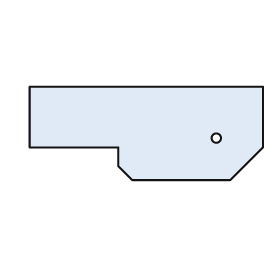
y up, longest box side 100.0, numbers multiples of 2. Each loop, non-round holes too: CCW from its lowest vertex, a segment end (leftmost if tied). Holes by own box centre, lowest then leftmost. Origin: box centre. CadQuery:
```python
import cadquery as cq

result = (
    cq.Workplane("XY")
    .moveTo(-6.0, -20.0)
    .lineTo(36.0, -20.0)
    .lineTo(50.0, -6.0)
    .lineTo(50.0, 20.0)
    .lineTo(-50.0, 20.0)
    .lineTo(-50.0, -6.0)
    .lineTo(-12.0, -6.0)
    .lineTo(-12.0, -14.0)
    .close()
    .moveTo(30.0, -2.0)
    .circle(2.0)
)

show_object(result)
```